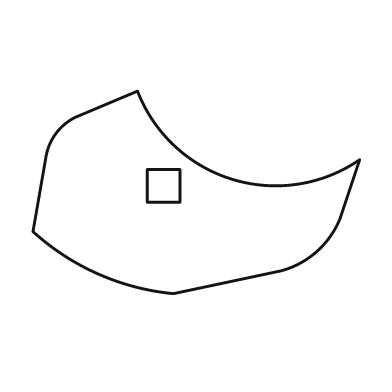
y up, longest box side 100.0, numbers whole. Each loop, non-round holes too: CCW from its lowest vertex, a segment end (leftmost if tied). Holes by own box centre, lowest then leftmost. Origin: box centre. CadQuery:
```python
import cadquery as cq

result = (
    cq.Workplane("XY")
    .moveTo(-7.0, -31.0)
    .lineTo(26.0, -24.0)
    .threePointArc((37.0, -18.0), (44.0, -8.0))
    .lineTo(50.0, 10.0)
    .threePointArc((11.0, 4.0), (-18.0, 31.0))
    .lineTo(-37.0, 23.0)
    .threePointArc((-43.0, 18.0), (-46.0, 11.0))
    .lineTo(-50.0, -12.0)
    .threePointArc((-30.0, -25.0), (-7.0, -31.0))
    .close()
    .moveTo(-15.0, -3.0)
    .lineTo(-5.0, -3.0)
    .lineTo(-5.0, 7.0)
    .lineTo(-15.0, 7.0)
    .close()
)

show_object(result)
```